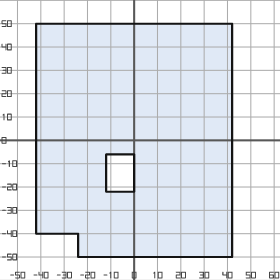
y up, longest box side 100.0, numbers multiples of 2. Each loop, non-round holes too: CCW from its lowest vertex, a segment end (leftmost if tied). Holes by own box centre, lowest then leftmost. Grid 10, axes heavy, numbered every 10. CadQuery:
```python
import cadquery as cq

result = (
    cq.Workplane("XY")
    .moveTo(-24.0, -50.0)
    .lineTo(42.0, -50.0)
    .lineTo(42.0, 50.0)
    .lineTo(-42.0, 50.0)
    .lineTo(-42.0, -40.0)
    .lineTo(-24.0, -40.0)
    .close()
    .moveTo(-12.0, -22.0)
    .lineTo(0.0, -22.0)
    .lineTo(0.0, -6.0)
    .lineTo(-12.0, -6.0)
    .close()
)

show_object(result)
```